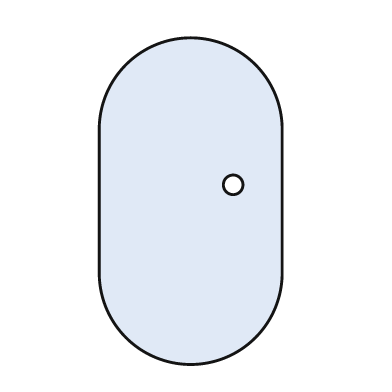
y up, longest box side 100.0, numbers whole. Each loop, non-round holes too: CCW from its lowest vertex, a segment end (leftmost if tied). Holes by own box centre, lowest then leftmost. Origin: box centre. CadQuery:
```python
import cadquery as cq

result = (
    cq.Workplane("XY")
    .moveTo(-28.0, -22.0)
    .threePointArc((0.0, -50.0), (28.0, -22.0))
    .lineTo(28.0, 22.0)
    .threePointArc((0.0, 50.0), (-28.0, 22.0))
    .close()
    .moveTo(13.0, 5.0)
    .circle(3.0)
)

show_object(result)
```